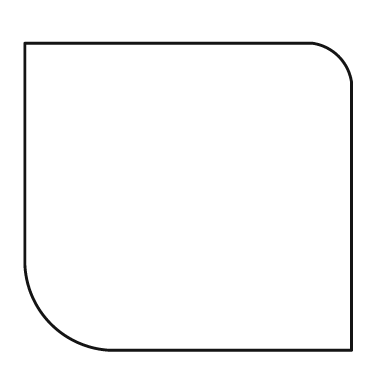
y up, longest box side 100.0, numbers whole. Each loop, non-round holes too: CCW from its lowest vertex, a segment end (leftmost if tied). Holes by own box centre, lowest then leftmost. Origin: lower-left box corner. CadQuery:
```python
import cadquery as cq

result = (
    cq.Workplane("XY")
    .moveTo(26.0, 0.0)
    .lineTo(100.0, 0.0)
    .lineTo(100.0, 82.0)
    .threePointArc((96.0, 90.0), (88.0, 94.0))
    .lineTo(0.0, 94.0)
    .lineTo(0.0, 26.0)
    .threePointArc((8.0, 8.0), (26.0, 0.0))
    .close()
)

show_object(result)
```